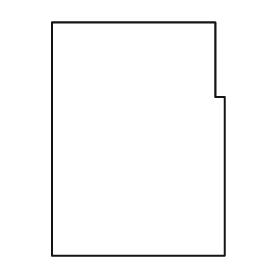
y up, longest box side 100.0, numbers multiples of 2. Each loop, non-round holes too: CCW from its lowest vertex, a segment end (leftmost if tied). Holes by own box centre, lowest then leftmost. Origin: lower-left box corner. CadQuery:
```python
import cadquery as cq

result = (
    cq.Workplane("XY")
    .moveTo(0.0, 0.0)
    .lineTo(74.0, 0.0)
    .lineTo(74.0, 68.0)
    .lineTo(70.0, 68.0)
    .lineTo(70.0, 100.0)
    .lineTo(0.0, 100.0)
    .close()
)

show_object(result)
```